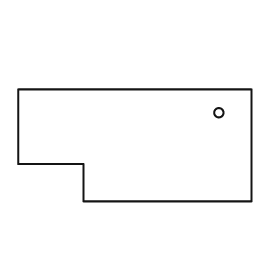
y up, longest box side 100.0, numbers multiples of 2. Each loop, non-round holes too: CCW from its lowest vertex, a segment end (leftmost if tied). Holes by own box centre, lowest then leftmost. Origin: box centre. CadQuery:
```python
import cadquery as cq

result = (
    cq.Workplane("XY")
    .moveTo(-22.0, -24.0)
    .lineTo(50.0, -24.0)
    .lineTo(50.0, 24.0)
    .lineTo(-50.0, 24.0)
    .lineTo(-50.0, -8.0)
    .lineTo(-22.0, -8.0)
    .close()
    .moveTo(36.0, 14.0)
    .circle(2.0)
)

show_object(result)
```